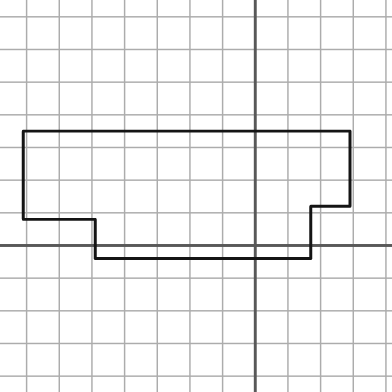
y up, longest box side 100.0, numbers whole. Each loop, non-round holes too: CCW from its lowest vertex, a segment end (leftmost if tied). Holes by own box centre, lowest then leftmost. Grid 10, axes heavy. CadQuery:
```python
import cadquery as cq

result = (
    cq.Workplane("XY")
    .moveTo(-49.0, -4.0)
    .lineTo(17.0, -4.0)
    .lineTo(17.0, 12.0)
    .lineTo(29.0, 12.0)
    .lineTo(29.0, 35.0)
    .lineTo(-71.0, 35.0)
    .lineTo(-71.0, 8.0)
    .lineTo(-49.0, 8.0)
    .close()
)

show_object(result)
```